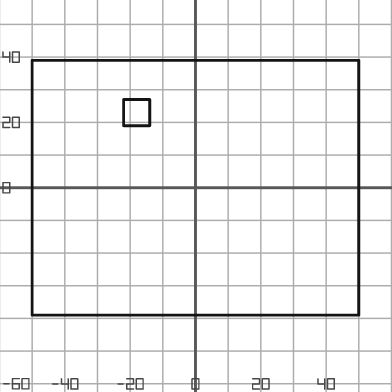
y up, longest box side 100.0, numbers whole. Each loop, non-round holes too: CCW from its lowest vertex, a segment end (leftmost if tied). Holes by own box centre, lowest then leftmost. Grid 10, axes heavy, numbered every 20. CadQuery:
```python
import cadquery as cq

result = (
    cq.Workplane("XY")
    .moveTo(-50.0, -39.0)
    .lineTo(50.0, -39.0)
    .lineTo(50.0, 39.0)
    .lineTo(-50.0, 39.0)
    .close()
    .moveTo(-22.0, 19.0)
    .lineTo(-14.0, 19.0)
    .lineTo(-14.0, 27.0)
    .lineTo(-22.0, 27.0)
    .close()
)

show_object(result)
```